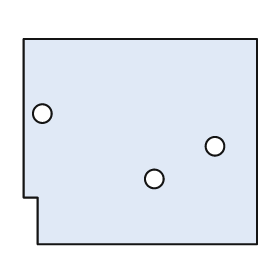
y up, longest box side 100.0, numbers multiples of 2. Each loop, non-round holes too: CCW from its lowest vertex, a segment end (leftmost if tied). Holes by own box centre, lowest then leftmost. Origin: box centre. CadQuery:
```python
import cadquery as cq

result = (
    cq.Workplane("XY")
    .moveTo(-44.0, -44.0)
    .lineTo(50.0, -44.0)
    .lineTo(50.0, 44.0)
    .lineTo(-50.0, 44.0)
    .lineTo(-50.0, -24.0)
    .lineTo(-44.0, -24.0)
    .close()
    .moveTo(6.0, -16.0)
    .circle(4.0)
    .moveTo(32.0, -2.0)
    .circle(4.0)
    .moveTo(-42.0, 12.0)
    .circle(4.0)
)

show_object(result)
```